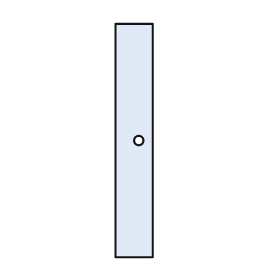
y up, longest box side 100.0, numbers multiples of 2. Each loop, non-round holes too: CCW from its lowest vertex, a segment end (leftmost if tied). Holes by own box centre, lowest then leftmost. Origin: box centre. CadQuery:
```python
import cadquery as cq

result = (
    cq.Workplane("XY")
    .moveTo(-8.0, -50.0)
    .lineTo(8.0, -50.0)
    .lineTo(8.0, 50.0)
    .lineTo(-8.0, 50.0)
    .close()
    .moveTo(2.0, 0.0)
    .circle(2.0)
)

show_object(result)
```